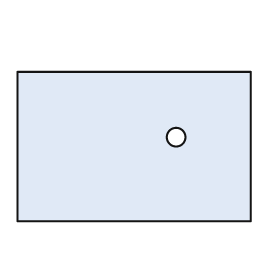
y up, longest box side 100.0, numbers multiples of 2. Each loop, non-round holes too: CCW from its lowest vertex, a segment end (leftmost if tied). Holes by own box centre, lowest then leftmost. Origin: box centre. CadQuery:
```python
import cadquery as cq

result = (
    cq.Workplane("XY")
    .moveTo(-50.0, -32.0)
    .lineTo(50.0, -32.0)
    .lineTo(50.0, 32.0)
    .lineTo(-50.0, 32.0)
    .close()
    .moveTo(18.0, 4.0)
    .circle(4.0)
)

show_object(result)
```